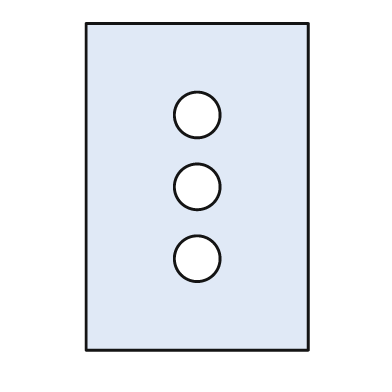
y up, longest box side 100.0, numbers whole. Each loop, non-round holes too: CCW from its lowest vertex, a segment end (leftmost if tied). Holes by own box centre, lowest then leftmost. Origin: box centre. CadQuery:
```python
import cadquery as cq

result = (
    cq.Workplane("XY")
    .moveTo(-34.0, -50.0)
    .lineTo(34.0, -50.0)
    .lineTo(34.0, 50.0)
    .lineTo(-34.0, 50.0)
    .close()
    .moveTo(0.0, -22.0)
    .circle(7.0)
    .moveTo(0.0, 0.0)
    .circle(7.0)
    .moveTo(0.0, 22.0)
    .circle(7.0)
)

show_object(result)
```